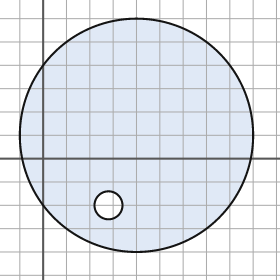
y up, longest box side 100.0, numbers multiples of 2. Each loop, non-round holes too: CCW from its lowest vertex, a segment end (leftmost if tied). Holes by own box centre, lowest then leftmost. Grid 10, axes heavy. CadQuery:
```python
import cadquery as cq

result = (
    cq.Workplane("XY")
    .moveTo(40.0, 10.0)
    .circle(50.0)
    .moveTo(28.0, -20.0)
    .circle(6.0)
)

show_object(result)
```